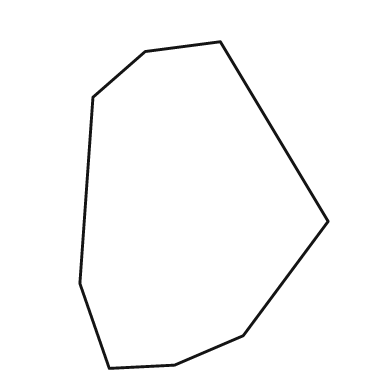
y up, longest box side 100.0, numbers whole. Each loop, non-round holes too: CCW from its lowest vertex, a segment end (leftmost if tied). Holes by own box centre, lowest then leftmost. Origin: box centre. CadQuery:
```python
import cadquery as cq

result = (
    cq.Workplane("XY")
    .moveTo(-29.0, -50.0)
    .lineTo(-9.0, -49.0)
    .lineTo(12.0, -40.0)
    .lineTo(38.0, -5.0)
    .lineTo(5.0, 50.0)
    .lineTo(-18.0, 47.0)
    .lineTo(-34.0, 33.0)
    .lineTo(-38.0, -24.0)
    .close()
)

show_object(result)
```